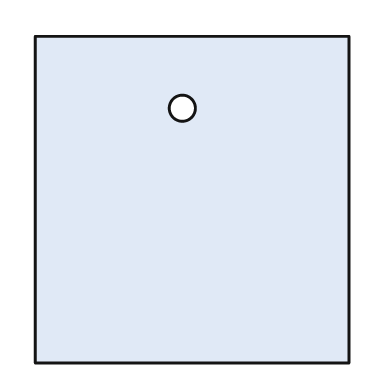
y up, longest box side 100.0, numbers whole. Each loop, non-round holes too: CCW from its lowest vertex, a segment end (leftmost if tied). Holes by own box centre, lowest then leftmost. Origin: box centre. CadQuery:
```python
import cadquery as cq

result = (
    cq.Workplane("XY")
    .moveTo(-48.0, -50.0)
    .lineTo(48.0, -50.0)
    .lineTo(48.0, 50.0)
    .lineTo(-48.0, 50.0)
    .close()
    .moveTo(-3.0, 28.0)
    .circle(4.0)
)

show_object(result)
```